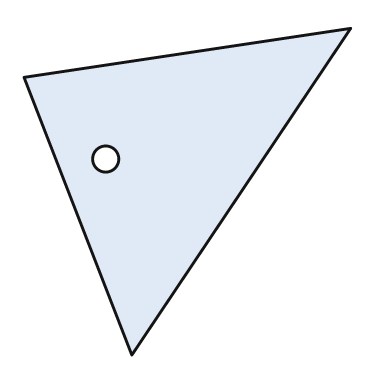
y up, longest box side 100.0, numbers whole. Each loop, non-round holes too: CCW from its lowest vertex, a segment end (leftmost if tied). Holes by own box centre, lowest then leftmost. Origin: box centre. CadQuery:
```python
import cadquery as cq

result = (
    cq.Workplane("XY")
    .moveTo(-17.0, -50.0)
    .lineTo(50.0, 50.0)
    .lineTo(-50.0, 35.0)
    .close()
    .moveTo(-25.0, 10.0)
    .circle(4.0)
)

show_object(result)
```